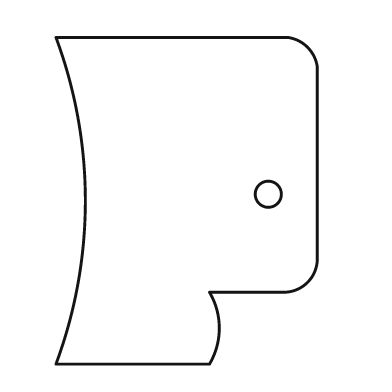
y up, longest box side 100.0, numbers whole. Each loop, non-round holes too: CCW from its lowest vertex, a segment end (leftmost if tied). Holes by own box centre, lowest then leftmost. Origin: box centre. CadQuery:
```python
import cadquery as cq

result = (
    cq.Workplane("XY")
    .moveTo(-40.0, -50.0)
    .lineTo(7.0, -50.0)
    .threePointArc((10.0, -39.0), (7.0, -28.0))
    .lineTo(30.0, -28.0)
    .threePointArc((37.0, -25.0), (40.0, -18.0))
    .lineTo(40.0, 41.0)
    .threePointArc((37.0, 47.0), (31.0, 50.0))
    .lineTo(-40.0, 50.0)
    .threePointArc((-31.0, 0.0), (-40.0, -50.0))
    .close()
    .moveTo(25.0, 2.0)
    .circle(4.0)
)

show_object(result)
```